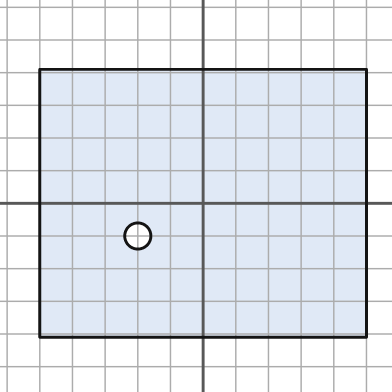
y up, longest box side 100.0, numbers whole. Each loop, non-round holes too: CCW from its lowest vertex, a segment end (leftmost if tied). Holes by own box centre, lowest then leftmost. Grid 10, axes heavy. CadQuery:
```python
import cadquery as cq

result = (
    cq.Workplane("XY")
    .moveTo(-50.0, -41.0)
    .lineTo(50.0, -41.0)
    .lineTo(50.0, 41.0)
    .lineTo(-50.0, 41.0)
    .close()
    .moveTo(-20.0, -10.0)
    .circle(4.0)
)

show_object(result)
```